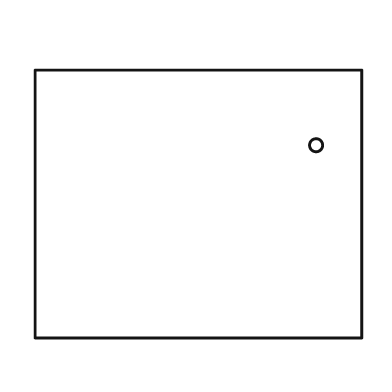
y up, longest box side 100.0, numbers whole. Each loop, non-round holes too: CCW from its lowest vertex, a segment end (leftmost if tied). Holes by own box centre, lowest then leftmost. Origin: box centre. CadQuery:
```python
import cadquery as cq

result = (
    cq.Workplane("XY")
    .moveTo(-50.0, -41.0)
    .lineTo(50.0, -41.0)
    .lineTo(50.0, 41.0)
    .lineTo(-50.0, 41.0)
    .close()
    .moveTo(36.0, 18.0)
    .circle(2.0)
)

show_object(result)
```